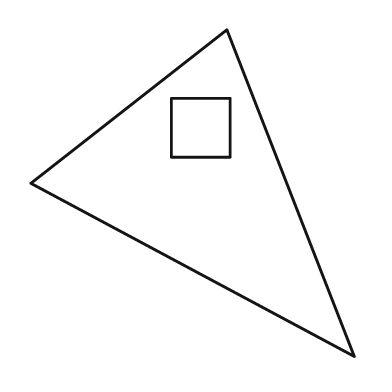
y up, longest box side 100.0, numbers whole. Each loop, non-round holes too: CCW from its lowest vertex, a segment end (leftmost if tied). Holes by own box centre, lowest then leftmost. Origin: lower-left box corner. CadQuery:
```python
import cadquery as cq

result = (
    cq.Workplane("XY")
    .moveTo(99.0, 0.0)
    .lineTo(60.0, 100.0)
    .lineTo(0.0, 53.0)
    .close()
    .moveTo(43.0, 61.0)
    .lineTo(61.0, 61.0)
    .lineTo(61.0, 79.0)
    .lineTo(43.0, 79.0)
    .close()
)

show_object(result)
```